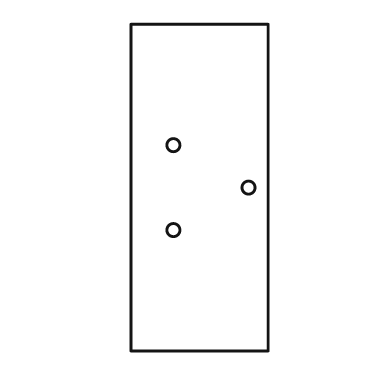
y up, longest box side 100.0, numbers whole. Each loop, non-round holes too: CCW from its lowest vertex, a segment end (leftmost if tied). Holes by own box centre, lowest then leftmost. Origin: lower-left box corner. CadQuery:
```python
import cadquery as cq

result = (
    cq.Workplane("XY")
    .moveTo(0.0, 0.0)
    .lineTo(42.0, 0.0)
    .lineTo(42.0, 100.0)
    .lineTo(0.0, 100.0)
    .close()
    .moveTo(13.0, 37.0)
    .circle(2.0)
    .moveTo(36.0, 50.0)
    .circle(2.0)
    .moveTo(13.0, 63.0)
    .circle(2.0)
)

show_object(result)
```